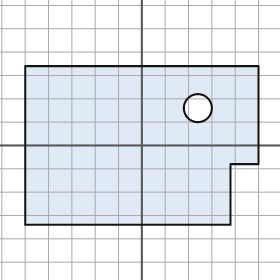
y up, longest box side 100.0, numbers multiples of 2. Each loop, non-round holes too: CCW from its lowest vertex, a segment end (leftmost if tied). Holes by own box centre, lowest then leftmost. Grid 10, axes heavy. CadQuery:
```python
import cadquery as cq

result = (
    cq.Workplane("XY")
    .moveTo(-50.0, -34.0)
    .lineTo(38.0, -34.0)
    .lineTo(38.0, -8.0)
    .lineTo(50.0, -8.0)
    .lineTo(50.0, 34.0)
    .lineTo(-50.0, 34.0)
    .close()
    .moveTo(24.0, 16.0)
    .circle(6.0)
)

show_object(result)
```